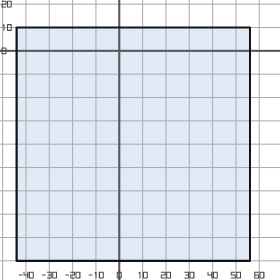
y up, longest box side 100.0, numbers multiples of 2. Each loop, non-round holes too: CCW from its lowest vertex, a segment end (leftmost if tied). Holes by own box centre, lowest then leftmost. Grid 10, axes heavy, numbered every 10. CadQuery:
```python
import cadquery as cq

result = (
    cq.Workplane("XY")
    .moveTo(-44.0, -90.0)
    .lineTo(56.0, -90.0)
    .lineTo(56.0, 10.0)
    .lineTo(-44.0, 10.0)
    .close()
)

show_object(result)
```